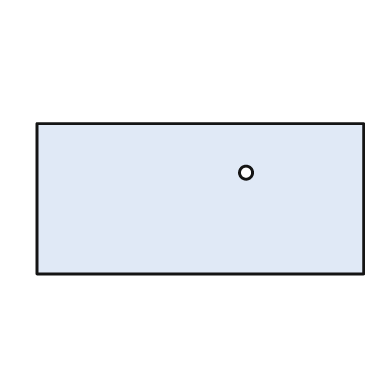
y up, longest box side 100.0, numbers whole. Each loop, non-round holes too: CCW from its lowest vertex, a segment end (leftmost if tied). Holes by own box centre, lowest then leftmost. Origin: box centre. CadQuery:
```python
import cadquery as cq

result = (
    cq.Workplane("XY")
    .moveTo(-50.0, -23.0)
    .lineTo(50.0, -23.0)
    .lineTo(50.0, 23.0)
    .lineTo(-50.0, 23.0)
    .close()
    .moveTo(14.0, 8.0)
    .circle(2.0)
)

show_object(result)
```